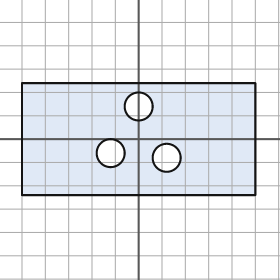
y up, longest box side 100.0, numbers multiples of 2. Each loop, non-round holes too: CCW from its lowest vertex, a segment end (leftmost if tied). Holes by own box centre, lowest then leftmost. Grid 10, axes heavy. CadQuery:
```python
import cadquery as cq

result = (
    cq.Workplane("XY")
    .moveTo(-50.0, -24.0)
    .lineTo(50.0, -24.0)
    .lineTo(50.0, 24.0)
    .lineTo(-50.0, 24.0)
    .close()
    .moveTo(12.0, -8.0)
    .circle(6.0)
    .moveTo(-12.0, -6.0)
    .circle(6.0)
    .moveTo(0.0, 14.0)
    .circle(6.0)
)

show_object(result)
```